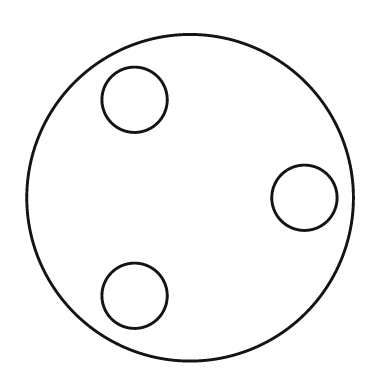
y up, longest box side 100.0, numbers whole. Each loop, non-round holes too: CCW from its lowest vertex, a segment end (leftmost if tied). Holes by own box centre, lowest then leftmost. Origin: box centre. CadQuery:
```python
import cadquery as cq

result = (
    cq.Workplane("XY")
    .moveTo(0.0, 0.0)
    .circle(50.0)
    .moveTo(-17.0, -30.0)
    .circle(10.0)
    .moveTo(35.0, 0.0)
    .circle(10.0)
    .moveTo(-17.0, 30.0)
    .circle(10.0)
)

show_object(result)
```